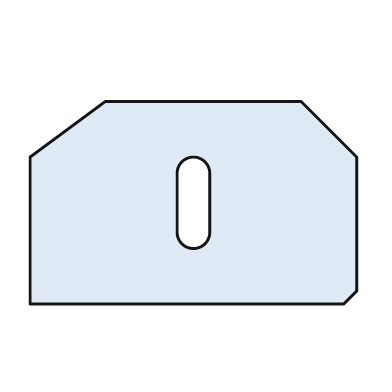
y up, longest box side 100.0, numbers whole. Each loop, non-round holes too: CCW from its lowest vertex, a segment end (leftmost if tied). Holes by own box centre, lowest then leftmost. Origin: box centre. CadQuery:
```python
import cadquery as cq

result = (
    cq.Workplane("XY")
    .moveTo(-50.0, -31.0)
    .lineTo(46.0, -31.0)
    .lineTo(50.0, -27.0)
    .lineTo(50.0, 14.0)
    .lineTo(33.0, 31.0)
    .lineTo(-27.0, 31.0)
    .lineTo(-50.0, 14.0)
    .close()
    .moveTo(-5.0, -9.0)
    .threePointArc((0.0, -14.0), (5.0, -9.0))
    .lineTo(5.0, 9.0)
    .threePointArc((0.0, 14.0), (-5.0, 9.0))
    .close()
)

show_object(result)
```